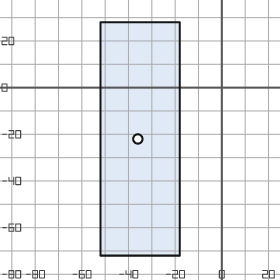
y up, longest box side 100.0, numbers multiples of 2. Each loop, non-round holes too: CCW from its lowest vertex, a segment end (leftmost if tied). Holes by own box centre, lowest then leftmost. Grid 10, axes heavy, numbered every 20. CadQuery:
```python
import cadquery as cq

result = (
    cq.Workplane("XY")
    .moveTo(-52.0, -72.0)
    .lineTo(-18.0, -72.0)
    .lineTo(-18.0, 28.0)
    .lineTo(-52.0, 28.0)
    .close()
    .moveTo(-36.0, -22.0)
    .circle(2.0)
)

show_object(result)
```